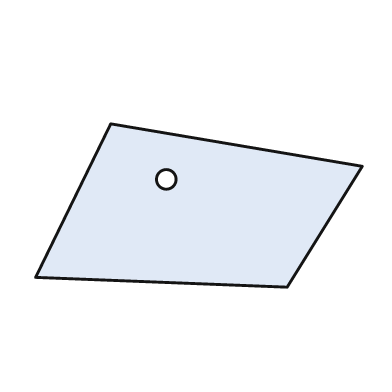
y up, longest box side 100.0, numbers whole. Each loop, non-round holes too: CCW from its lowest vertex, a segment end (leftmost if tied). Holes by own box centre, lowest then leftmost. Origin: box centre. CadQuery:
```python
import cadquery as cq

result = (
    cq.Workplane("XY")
    .moveTo(27.0, -25.0)
    .lineTo(50.0, 12.0)
    .lineTo(-27.0, 25.0)
    .lineTo(-50.0, -22.0)
    .close()
    .moveTo(-10.0, 8.0)
    .circle(3.0)
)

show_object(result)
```